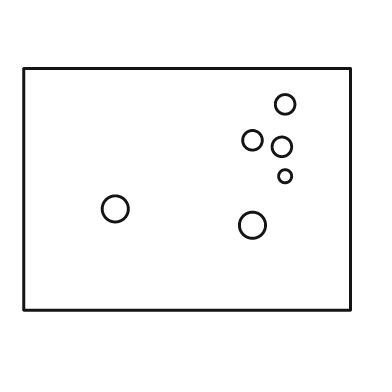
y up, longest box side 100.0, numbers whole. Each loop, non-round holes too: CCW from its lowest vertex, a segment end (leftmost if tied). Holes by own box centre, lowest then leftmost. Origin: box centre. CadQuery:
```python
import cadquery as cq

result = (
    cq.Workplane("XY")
    .moveTo(-50.0, -37.0)
    .lineTo(50.0, -37.0)
    .lineTo(50.0, 37.0)
    .lineTo(-50.0, 37.0)
    .close()
    .moveTo(20.0, -11.0)
    .circle(4.0)
    .moveTo(-22.0, -6.0)
    .circle(4.0)
    .moveTo(30.0, 4.0)
    .circle(2.0)
    .moveTo(29.0, 13.0)
    .circle(3.0)
    .moveTo(20.0, 15.0)
    .circle(3.0)
    .moveTo(30.0, 26.0)
    .circle(3.0)
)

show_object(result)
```